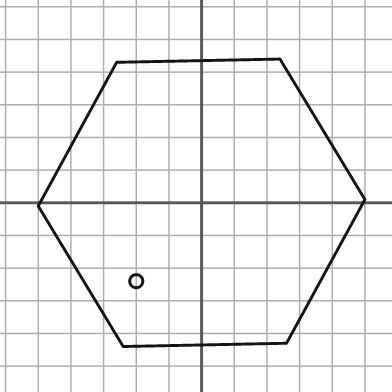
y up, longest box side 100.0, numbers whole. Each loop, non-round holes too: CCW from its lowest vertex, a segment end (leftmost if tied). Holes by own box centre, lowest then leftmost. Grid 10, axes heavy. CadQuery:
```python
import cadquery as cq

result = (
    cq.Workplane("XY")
    .moveTo(-24.0, -44.0)
    .lineTo(26.0, -43.0)
    .lineTo(50.0, 1.0)
    .lineTo(24.0, 44.0)
    .lineTo(-26.0, 43.0)
    .lineTo(-50.0, -1.0)
    .close()
    .moveTo(-20.0, -24.0)
    .circle(2.0)
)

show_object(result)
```